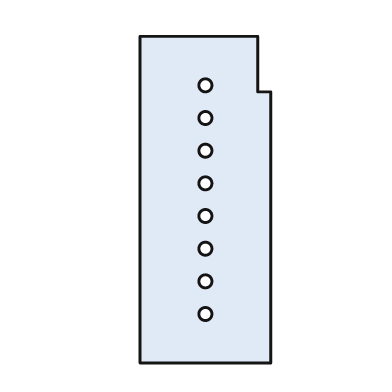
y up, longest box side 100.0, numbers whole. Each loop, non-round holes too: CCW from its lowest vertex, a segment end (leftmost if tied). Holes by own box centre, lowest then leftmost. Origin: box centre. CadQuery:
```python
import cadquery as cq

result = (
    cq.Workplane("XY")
    .moveTo(-20.0, -50.0)
    .lineTo(20.0, -50.0)
    .lineTo(20.0, 33.0)
    .lineTo(16.0, 33.0)
    .lineTo(16.0, 50.0)
    .lineTo(-20.0, 50.0)
    .close()
    .moveTo(0.0, -35.0)
    .circle(2.0)
    .moveTo(0.0, -25.0)
    .circle(2.0)
    .moveTo(0.0, -15.0)
    .circle(2.0)
    .moveTo(0.0, -5.0)
    .circle(2.0)
    .moveTo(0.0, 5.0)
    .circle(2.0)
    .moveTo(0.0, 15.0)
    .circle(2.0)
    .moveTo(0.0, 25.0)
    .circle(2.0)
    .moveTo(0.0, 35.0)
    .circle(2.0)
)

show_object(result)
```